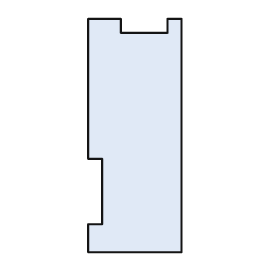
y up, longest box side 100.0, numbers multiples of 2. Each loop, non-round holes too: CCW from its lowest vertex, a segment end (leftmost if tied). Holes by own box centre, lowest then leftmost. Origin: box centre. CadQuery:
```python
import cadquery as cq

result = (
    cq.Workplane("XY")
    .moveTo(-20.0, -50.0)
    .lineTo(20.0, -50.0)
    .lineTo(20.0, 50.0)
    .lineTo(14.0, 50.0)
    .lineTo(14.0, 44.0)
    .lineTo(-6.0, 44.0)
    .lineTo(-6.0, 50.0)
    .lineTo(-20.0, 50.0)
    .lineTo(-20.0, -10.0)
    .lineTo(-14.0, -10.0)
    .lineTo(-14.0, -38.0)
    .lineTo(-20.0, -38.0)
    .close()
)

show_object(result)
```